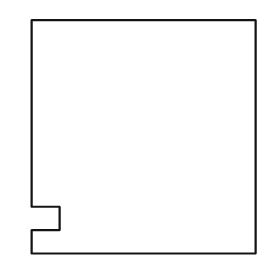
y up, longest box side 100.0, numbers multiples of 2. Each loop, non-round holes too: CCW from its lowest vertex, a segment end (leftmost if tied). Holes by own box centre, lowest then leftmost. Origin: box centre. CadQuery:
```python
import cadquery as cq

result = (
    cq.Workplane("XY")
    .moveTo(-48.0, -50.0)
    .lineTo(48.0, -50.0)
    .lineTo(48.0, 50.0)
    .lineTo(-48.0, 50.0)
    .lineTo(-48.0, -30.0)
    .lineTo(-36.0, -30.0)
    .lineTo(-36.0, -40.0)
    .lineTo(-48.0, -40.0)
    .close()
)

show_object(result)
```